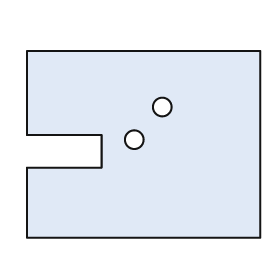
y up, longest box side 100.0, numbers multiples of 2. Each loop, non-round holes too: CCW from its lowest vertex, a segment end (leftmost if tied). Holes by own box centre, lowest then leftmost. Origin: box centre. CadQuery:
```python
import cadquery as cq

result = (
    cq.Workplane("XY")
    .moveTo(-50.0, -40.0)
    .lineTo(50.0, -40.0)
    .lineTo(50.0, 40.0)
    .lineTo(-50.0, 40.0)
    .lineTo(-50.0, 4.0)
    .lineTo(-18.0, 4.0)
    .lineTo(-18.0, -10.0)
    .lineTo(-50.0, -10.0)
    .close()
    .moveTo(-4.0, 2.0)
    .circle(4.0)
    .moveTo(8.0, 16.0)
    .circle(4.0)
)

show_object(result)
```